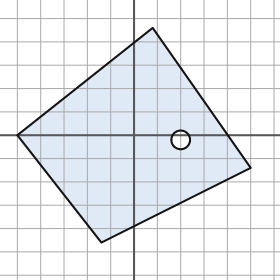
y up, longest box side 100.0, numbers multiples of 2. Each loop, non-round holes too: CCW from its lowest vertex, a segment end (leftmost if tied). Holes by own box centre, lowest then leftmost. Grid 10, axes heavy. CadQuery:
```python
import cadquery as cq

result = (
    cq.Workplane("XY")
    .moveTo(-14.0, -46.0)
    .lineTo(50.0, -14.0)
    .lineTo(8.0, 46.0)
    .lineTo(-50.0, 0.0)
    .close()
    .moveTo(20.0, -2.0)
    .circle(4.0)
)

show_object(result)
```